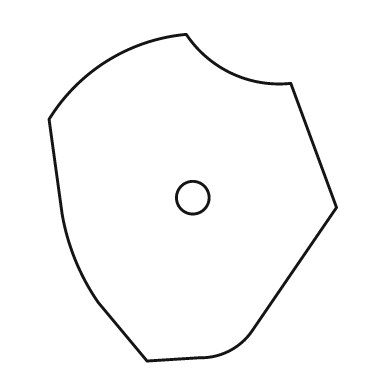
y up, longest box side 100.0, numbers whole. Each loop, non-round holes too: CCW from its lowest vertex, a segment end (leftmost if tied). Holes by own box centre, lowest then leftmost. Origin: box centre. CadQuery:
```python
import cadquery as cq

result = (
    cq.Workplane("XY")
    .moveTo(-14.0, -50.0)
    .lineTo(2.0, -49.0)
    .threePointArc((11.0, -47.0), (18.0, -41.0))
    .lineTo(44.0, -3.0)
    .lineTo(30.0, 35.0)
    .threePointArc((12.0, 38.0), (-2.0, 50.0))
    .threePointArc((-26.0, 42.0), (-44.0, 24.0))
    .lineTo(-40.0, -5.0)
    .threePointArc((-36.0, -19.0), (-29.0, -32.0))
    .close()
    .moveTo(0.0, 0.0)
    .circle(5.0)
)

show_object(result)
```